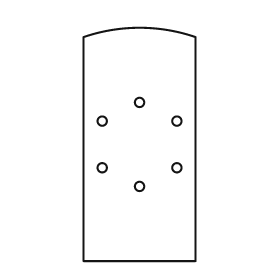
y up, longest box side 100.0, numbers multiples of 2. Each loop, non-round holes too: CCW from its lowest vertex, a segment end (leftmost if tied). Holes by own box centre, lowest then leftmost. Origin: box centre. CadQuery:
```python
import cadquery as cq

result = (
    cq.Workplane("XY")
    .moveTo(-24.0, -50.0)
    .lineTo(24.0, -50.0)
    .lineTo(24.0, 46.0)
    .threePointArc((0.0, 50.0), (-24.0, 46.0))
    .close()
    .moveTo(0.0, -18.0)
    .circle(2.0)
    .moveTo(-16.0, -10.0)
    .circle(2.0)
    .moveTo(16.0, -10.0)
    .circle(2.0)
    .moveTo(-16.0, 10.0)
    .circle(2.0)
    .moveTo(16.0, 10.0)
    .circle(2.0)
    .moveTo(0.0, 18.0)
    .circle(2.0)
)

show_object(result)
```